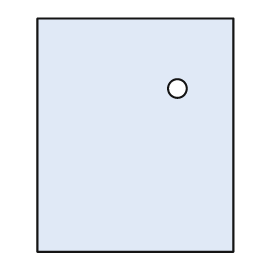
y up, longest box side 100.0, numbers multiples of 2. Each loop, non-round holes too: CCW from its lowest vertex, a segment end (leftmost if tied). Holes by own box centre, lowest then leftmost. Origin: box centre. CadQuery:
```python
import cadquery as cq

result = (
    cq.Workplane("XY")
    .moveTo(-42.0, -50.0)
    .lineTo(42.0, -50.0)
    .lineTo(42.0, 50.0)
    .lineTo(-42.0, 50.0)
    .close()
    .moveTo(18.0, 20.0)
    .circle(4.0)
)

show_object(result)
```